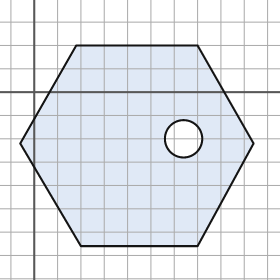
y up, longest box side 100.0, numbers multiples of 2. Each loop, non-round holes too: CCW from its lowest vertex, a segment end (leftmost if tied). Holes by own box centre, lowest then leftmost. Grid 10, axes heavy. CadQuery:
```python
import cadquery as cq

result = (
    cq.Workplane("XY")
    .moveTo(20.0, -66.0)
    .lineTo(70.0, -66.0)
    .lineTo(94.0, -22.0)
    .lineTo(70.0, 20.0)
    .lineTo(18.0, 20.0)
    .lineTo(-6.0, -22.0)
    .close()
    .moveTo(64.0, -20.0)
    .circle(8.0)
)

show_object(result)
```